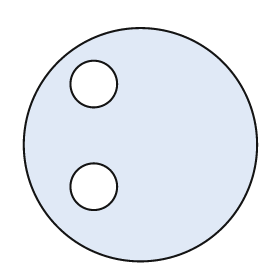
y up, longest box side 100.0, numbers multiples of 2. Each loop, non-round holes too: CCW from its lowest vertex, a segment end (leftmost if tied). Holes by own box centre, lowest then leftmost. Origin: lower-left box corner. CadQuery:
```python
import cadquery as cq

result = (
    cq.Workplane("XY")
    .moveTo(50.0, 50.0)
    .circle(50.0)
    .moveTo(30.0, 32.0)
    .circle(10.0)
    .moveTo(30.0, 76.0)
    .circle(10.0)
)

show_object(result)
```